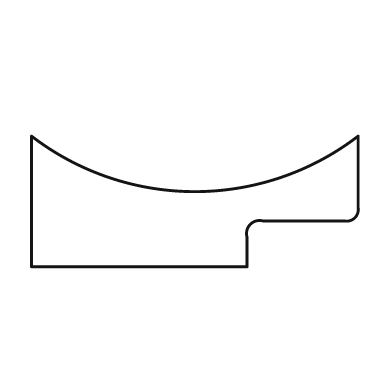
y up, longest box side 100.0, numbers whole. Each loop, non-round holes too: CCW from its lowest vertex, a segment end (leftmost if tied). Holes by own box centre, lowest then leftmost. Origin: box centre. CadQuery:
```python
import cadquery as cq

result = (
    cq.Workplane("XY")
    .moveTo(-50.0, -20.0)
    .lineTo(16.0, -20.0)
    .lineTo(16.0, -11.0)
    .threePointArc((17.0, -7.0), (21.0, -6.0))
    .lineTo(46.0, -6.0)
    .threePointArc((49.0, -5.0), (50.0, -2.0))
    .lineTo(50.0, 20.0)
    .threePointArc((0.0, 3.0), (-50.0, 20.0))
    .close()
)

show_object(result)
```